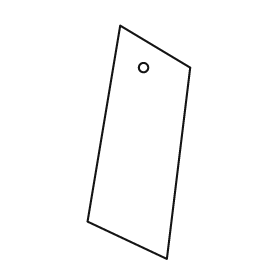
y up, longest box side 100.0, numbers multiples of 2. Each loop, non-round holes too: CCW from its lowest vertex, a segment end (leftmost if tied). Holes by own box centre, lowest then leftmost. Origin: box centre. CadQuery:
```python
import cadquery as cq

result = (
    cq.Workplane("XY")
    .moveTo(12.0, -50.0)
    .lineTo(22.0, 32.0)
    .lineTo(-8.0, 50.0)
    .lineTo(-22.0, -34.0)
    .close()
    .moveTo(2.0, 32.0)
    .circle(2.0)
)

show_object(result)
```